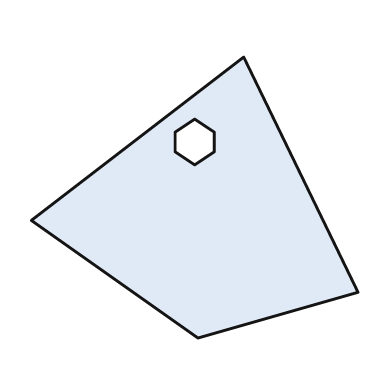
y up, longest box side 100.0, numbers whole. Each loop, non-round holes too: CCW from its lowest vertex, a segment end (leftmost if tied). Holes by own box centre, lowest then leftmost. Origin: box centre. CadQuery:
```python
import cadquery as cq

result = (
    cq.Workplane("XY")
    .moveTo(1.0, -43.0)
    .lineTo(50.0, -29.0)
    .lineTo(15.0, 43.0)
    .lineTo(-50.0, -7.0)
    .close()
    .moveTo(0.0, 10.0)
    .lineTo(6.0, 14.0)
    .lineTo(6.0, 20.0)
    .lineTo(0.0, 24.0)
    .lineTo(-6.0, 20.0)
    .lineTo(-6.0, 14.0)
    .close()
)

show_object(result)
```